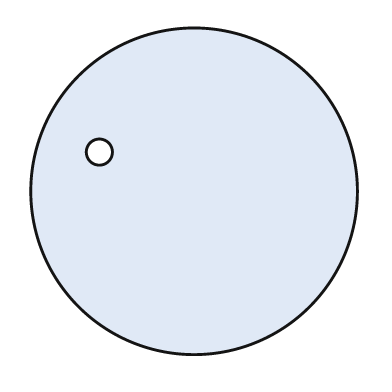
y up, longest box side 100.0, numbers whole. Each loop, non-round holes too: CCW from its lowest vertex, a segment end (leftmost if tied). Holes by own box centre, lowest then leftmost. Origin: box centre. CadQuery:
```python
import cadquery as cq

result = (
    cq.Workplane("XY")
    .moveTo(0.0, 0.0)
    .circle(50.0)
    .moveTo(-29.0, 12.0)
    .circle(4.0)
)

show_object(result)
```